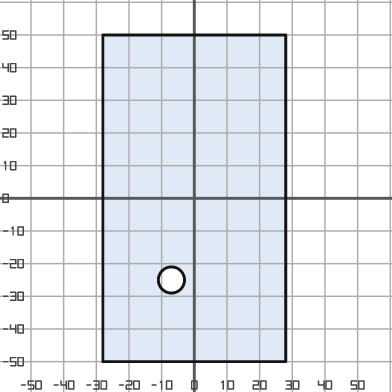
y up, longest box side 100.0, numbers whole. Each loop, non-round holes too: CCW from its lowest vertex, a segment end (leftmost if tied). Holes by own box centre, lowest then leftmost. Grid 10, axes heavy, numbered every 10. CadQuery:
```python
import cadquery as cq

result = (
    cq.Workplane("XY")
    .moveTo(-28.0, -50.0)
    .lineTo(28.0, -50.0)
    .lineTo(28.0, 50.0)
    .lineTo(-28.0, 50.0)
    .close()
    .moveTo(-7.0, -25.0)
    .circle(4.0)
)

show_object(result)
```